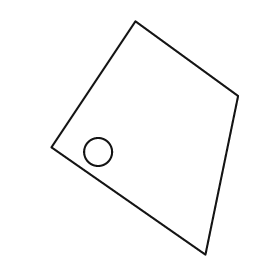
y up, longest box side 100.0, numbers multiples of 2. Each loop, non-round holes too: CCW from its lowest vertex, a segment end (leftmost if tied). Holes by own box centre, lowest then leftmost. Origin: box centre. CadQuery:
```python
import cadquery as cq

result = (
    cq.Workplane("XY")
    .moveTo(26.0, -50.0)
    .lineTo(40.0, 18.0)
    .lineTo(-4.0, 50.0)
    .lineTo(-40.0, -4.0)
    .close()
    .moveTo(-20.0, -6.0)
    .circle(6.0)
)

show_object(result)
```